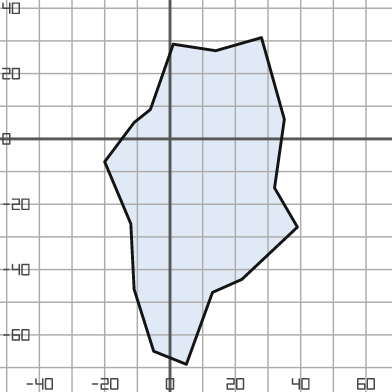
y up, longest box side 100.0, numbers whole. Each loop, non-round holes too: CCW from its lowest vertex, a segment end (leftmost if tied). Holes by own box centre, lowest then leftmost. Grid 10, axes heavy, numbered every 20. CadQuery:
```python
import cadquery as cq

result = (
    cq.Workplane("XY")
    .moveTo(5.0, -69.0)
    .lineTo(13.0, -47.0)
    .lineTo(22.0, -43.0)
    .lineTo(39.0, -27.0)
    .lineTo(32.0, -15.0)
    .lineTo(35.0, 6.0)
    .lineTo(28.0, 31.0)
    .lineTo(14.0, 27.0)
    .lineTo(1.0, 29.0)
    .lineTo(-6.0, 9.0)
    .lineTo(-11.0, 5.0)
    .lineTo(-20.0, -7.0)
    .lineTo(-12.0, -26.0)
    .lineTo(-11.0, -46.0)
    .lineTo(-5.0, -65.0)
    .close()
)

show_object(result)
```